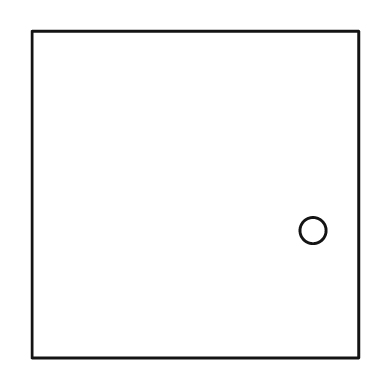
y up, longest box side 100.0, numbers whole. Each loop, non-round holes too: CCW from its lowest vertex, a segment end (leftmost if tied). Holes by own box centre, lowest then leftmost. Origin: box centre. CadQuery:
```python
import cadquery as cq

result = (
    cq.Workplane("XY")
    .moveTo(-50.0, -50.0)
    .lineTo(50.0, -50.0)
    .lineTo(50.0, 50.0)
    .lineTo(-50.0, 50.0)
    .close()
    .moveTo(36.0, -11.0)
    .circle(4.0)
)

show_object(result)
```